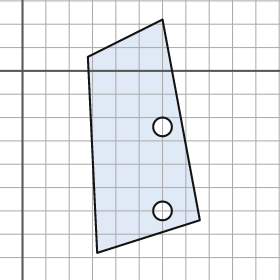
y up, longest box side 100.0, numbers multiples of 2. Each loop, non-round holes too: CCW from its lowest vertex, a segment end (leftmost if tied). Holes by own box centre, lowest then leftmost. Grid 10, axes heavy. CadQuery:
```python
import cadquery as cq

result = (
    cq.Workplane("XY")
    .moveTo(32.0, -78.0)
    .lineTo(76.0, -64.0)
    .lineTo(60.0, 22.0)
    .lineTo(28.0, 6.0)
    .close()
    .moveTo(60.0, -60.0)
    .circle(4.0)
    .moveTo(60.0, -24.0)
    .circle(4.0)
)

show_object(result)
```